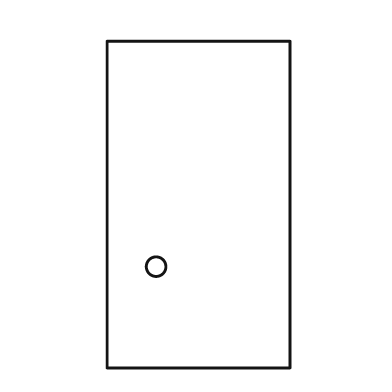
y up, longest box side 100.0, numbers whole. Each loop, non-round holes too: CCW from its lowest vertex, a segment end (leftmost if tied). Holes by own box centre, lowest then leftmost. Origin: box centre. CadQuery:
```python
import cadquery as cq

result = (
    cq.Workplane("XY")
    .moveTo(-28.0, -50.0)
    .lineTo(28.0, -50.0)
    .lineTo(28.0, 50.0)
    .lineTo(-28.0, 50.0)
    .close()
    .moveTo(-13.0, -19.0)
    .circle(3.0)
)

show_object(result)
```